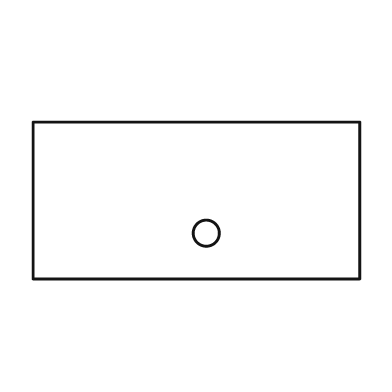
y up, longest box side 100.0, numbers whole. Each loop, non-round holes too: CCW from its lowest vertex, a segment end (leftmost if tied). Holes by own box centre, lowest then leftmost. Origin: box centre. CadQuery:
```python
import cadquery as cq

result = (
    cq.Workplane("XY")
    .moveTo(-50.0, -24.0)
    .lineTo(50.0, -24.0)
    .lineTo(50.0, 24.0)
    .lineTo(-50.0, 24.0)
    .close()
    .moveTo(3.0, -10.0)
    .circle(4.0)
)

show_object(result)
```